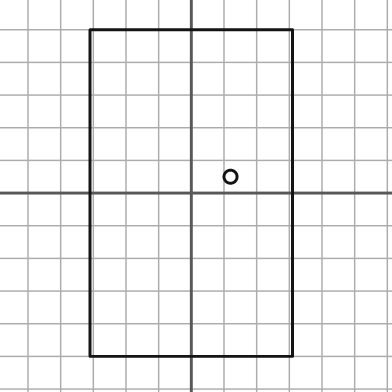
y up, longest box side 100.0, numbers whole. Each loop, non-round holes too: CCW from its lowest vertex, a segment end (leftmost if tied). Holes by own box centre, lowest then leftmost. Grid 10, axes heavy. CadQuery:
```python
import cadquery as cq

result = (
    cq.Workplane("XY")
    .moveTo(-31.0, -50.0)
    .lineTo(31.0, -50.0)
    .lineTo(31.0, 50.0)
    .lineTo(-31.0, 50.0)
    .close()
    .moveTo(12.0, 5.0)
    .circle(2.0)
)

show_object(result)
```